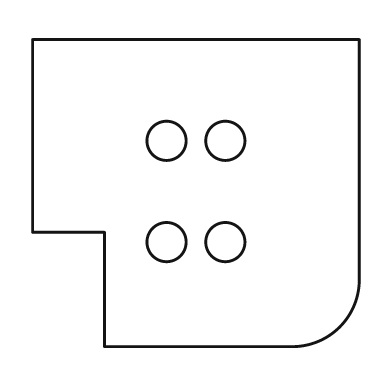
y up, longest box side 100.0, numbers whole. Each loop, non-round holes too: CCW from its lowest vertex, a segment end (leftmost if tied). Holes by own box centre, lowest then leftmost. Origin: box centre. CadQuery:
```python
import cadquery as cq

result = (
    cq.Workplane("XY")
    .moveTo(-28.0, -47.0)
    .lineTo(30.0, -47.0)
    .threePointArc((44.0, -41.0), (50.0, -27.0))
    .lineTo(50.0, 47.0)
    .lineTo(-50.0, 47.0)
    .lineTo(-50.0, -12.0)
    .lineTo(-28.0, -12.0)
    .close()
    .moveTo(-9.0, -15.0)
    .circle(6.0)
    .moveTo(9.0, -15.0)
    .circle(6.0)
    .moveTo(-9.0, 16.0)
    .circle(6.0)
    .moveTo(9.0, 16.0)
    .circle(6.0)
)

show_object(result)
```